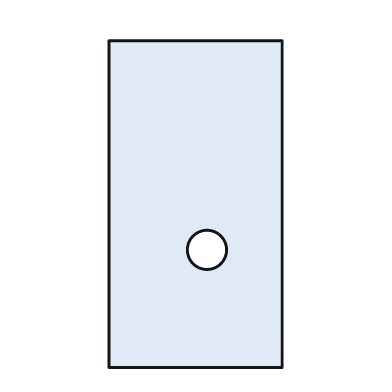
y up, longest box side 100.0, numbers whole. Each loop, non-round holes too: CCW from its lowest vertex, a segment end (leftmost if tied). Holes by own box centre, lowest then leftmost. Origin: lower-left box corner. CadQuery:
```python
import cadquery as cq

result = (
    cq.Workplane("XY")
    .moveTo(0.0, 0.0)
    .lineTo(53.0, 0.0)
    .lineTo(53.0, 100.0)
    .lineTo(0.0, 100.0)
    .close()
    .moveTo(30.0, 36.0)
    .circle(6.0)
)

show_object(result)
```